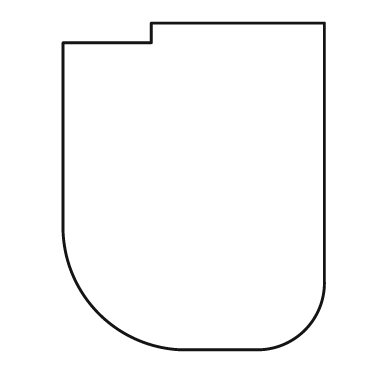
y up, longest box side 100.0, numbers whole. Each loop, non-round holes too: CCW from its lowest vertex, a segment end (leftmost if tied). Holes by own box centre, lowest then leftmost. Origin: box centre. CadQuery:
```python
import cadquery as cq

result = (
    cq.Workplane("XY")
    .moveTo(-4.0, -50.0)
    .lineTo(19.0, -50.0)
    .threePointArc((34.0, -44.0), (40.0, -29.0))
    .lineTo(40.0, 50.0)
    .lineTo(-13.0, 50.0)
    .lineTo(-13.0, 44.0)
    .lineTo(-40.0, 44.0)
    .lineTo(-40.0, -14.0)
    .threePointArc((-29.0, -39.0), (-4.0, -50.0))
    .close()
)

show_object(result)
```